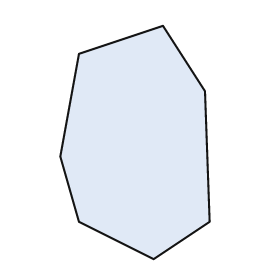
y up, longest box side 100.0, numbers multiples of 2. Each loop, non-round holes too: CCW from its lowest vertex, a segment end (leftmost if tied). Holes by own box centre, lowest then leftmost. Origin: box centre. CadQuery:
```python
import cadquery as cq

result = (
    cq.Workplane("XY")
    .moveTo(8.0, -50.0)
    .lineTo(32.0, -34.0)
    .lineTo(30.0, 22.0)
    .lineTo(12.0, 50.0)
    .lineTo(-24.0, 38.0)
    .lineTo(-32.0, -6.0)
    .lineTo(-24.0, -34.0)
    .close()
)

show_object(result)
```